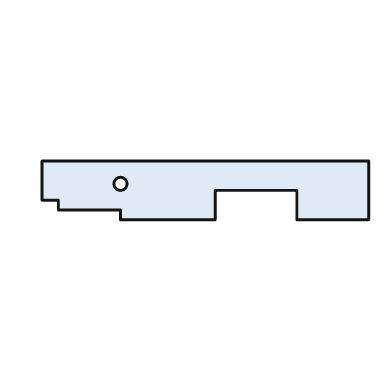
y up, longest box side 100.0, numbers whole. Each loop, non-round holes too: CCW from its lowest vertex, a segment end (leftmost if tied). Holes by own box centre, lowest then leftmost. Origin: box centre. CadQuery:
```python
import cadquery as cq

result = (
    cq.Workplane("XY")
    .moveTo(-26.0, -9.0)
    .lineTo(3.0, -9.0)
    .lineTo(3.0, 0.0)
    .lineTo(28.0, 0.0)
    .lineTo(28.0, -9.0)
    .lineTo(50.0, -9.0)
    .lineTo(50.0, 9.0)
    .lineTo(-50.0, 9.0)
    .lineTo(-50.0, -3.0)
    .lineTo(-45.0, -3.0)
    .lineTo(-45.0, -6.0)
    .lineTo(-26.0, -6.0)
    .close()
    .moveTo(-26.0, 2.0)
    .circle(2.0)
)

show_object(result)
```